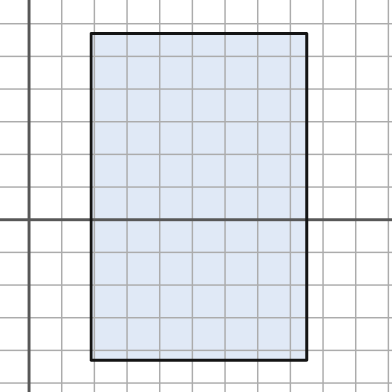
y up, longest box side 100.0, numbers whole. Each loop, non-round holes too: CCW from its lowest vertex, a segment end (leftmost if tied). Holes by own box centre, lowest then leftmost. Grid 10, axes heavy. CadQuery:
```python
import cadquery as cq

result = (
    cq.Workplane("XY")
    .moveTo(19.0, -43.0)
    .lineTo(85.0, -43.0)
    .lineTo(85.0, 57.0)
    .lineTo(19.0, 57.0)
    .close()
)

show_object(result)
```